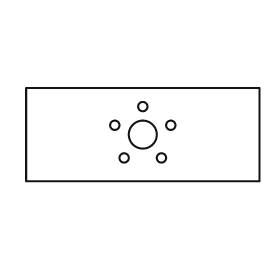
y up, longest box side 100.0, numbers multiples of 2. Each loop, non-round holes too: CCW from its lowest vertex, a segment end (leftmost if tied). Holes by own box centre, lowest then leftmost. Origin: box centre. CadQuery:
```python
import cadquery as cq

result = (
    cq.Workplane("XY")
    .moveTo(-50.0, -20.0)
    .lineTo(50.0, -20.0)
    .lineTo(50.0, 20.0)
    .lineTo(-50.0, 20.0)
    .close()
    .moveTo(-8.0, -10.0)
    .circle(2.0)
    .moveTo(8.0, -10.0)
    .circle(2.0)
    .moveTo(0.0, 0.0)
    .circle(6.0)
    .moveTo(-12.0, 4.0)
    .circle(2.0)
    .moveTo(12.0, 4.0)
    .circle(2.0)
    .moveTo(0.0, 12.0)
    .circle(2.0)
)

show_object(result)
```